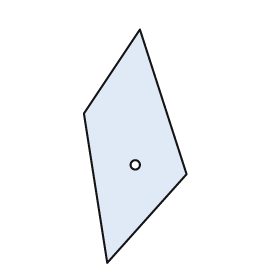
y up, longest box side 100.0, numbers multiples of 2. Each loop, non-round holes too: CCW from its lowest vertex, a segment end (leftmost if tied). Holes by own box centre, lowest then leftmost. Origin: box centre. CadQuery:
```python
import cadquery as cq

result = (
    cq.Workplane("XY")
    .moveTo(-12.0, -50.0)
    .lineTo(22.0, -12.0)
    .lineTo(2.0, 50.0)
    .lineTo(-22.0, 14.0)
    .close()
    .moveTo(0.0, -8.0)
    .circle(2.0)
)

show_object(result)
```